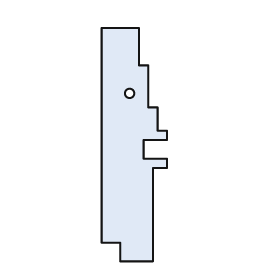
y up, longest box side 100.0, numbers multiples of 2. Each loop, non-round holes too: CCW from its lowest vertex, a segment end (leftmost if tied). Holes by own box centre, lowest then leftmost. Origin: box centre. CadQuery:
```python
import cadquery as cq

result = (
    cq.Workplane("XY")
    .moveTo(-6.0, -50.0)
    .lineTo(8.0, -50.0)
    .lineTo(8.0, -10.0)
    .lineTo(14.0, -10.0)
    .lineTo(14.0, -6.0)
    .lineTo(4.0, -6.0)
    .lineTo(4.0, 2.0)
    .lineTo(14.0, 2.0)
    .lineTo(14.0, 6.0)
    .lineTo(10.0, 6.0)
    .lineTo(10.0, 16.0)
    .lineTo(6.0, 16.0)
    .lineTo(6.0, 34.0)
    .lineTo(2.0, 34.0)
    .lineTo(2.0, 50.0)
    .lineTo(-14.0, 50.0)
    .lineTo(-14.0, -42.0)
    .lineTo(-6.0, -42.0)
    .close()
    .moveTo(-2.0, 22.0)
    .circle(2.0)
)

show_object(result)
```